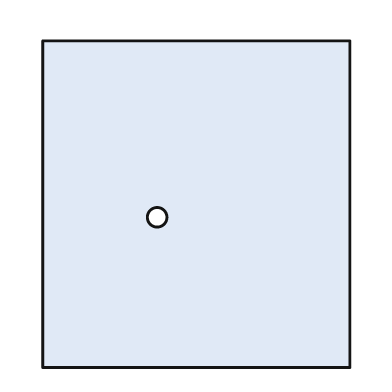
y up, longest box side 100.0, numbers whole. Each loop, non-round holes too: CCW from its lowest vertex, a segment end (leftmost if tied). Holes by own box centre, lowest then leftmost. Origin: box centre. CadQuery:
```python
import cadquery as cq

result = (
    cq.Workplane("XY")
    .moveTo(-47.0, -50.0)
    .lineTo(47.0, -50.0)
    .lineTo(47.0, 50.0)
    .lineTo(-47.0, 50.0)
    .close()
    .moveTo(-12.0, -4.0)
    .circle(3.0)
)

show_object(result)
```